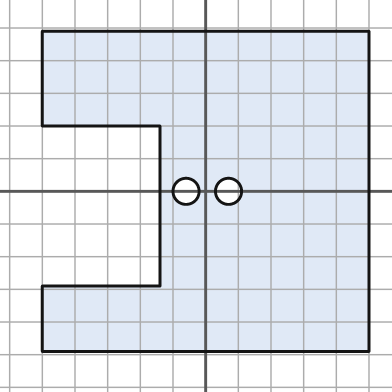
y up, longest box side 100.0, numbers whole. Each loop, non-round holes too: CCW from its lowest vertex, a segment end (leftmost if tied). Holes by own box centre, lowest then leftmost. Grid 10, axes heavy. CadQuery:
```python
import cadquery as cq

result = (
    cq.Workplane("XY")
    .moveTo(-50.0, -49.0)
    .lineTo(50.0, -49.0)
    .lineTo(50.0, 49.0)
    .lineTo(-50.0, 49.0)
    .lineTo(-50.0, 20.0)
    .lineTo(-14.0, 20.0)
    .lineTo(-14.0, -29.0)
    .lineTo(-50.0, -29.0)
    .close()
    .moveTo(-6.0, 0.0)
    .circle(4.0)
    .moveTo(7.0, 0.0)
    .circle(4.0)
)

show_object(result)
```